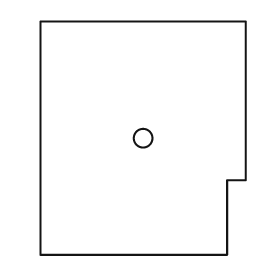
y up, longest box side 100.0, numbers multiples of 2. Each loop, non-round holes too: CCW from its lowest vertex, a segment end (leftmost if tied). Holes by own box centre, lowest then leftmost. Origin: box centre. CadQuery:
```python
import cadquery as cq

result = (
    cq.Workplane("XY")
    .moveTo(-44.0, -50.0)
    .lineTo(36.0, -50.0)
    .lineTo(36.0, -18.0)
    .lineTo(44.0, -18.0)
    .lineTo(44.0, 50.0)
    .lineTo(-44.0, 50.0)
    .close()
    .moveTo(0.0, 0.0)
    .circle(4.0)
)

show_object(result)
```